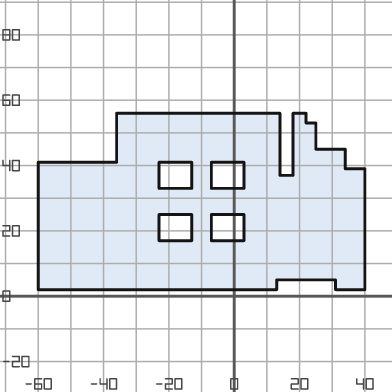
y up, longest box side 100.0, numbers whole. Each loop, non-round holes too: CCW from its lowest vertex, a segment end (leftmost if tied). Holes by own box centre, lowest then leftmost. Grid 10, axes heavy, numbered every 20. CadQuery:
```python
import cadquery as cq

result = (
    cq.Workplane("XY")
    .moveTo(-60.0, 2.0)
    .lineTo(13.0, 2.0)
    .lineTo(13.0, 5.0)
    .lineTo(31.0, 5.0)
    .lineTo(31.0, 2.0)
    .lineTo(40.0, 2.0)
    .lineTo(40.0, 39.0)
    .lineTo(34.0, 39.0)
    .lineTo(34.0, 45.0)
    .lineTo(25.0, 45.0)
    .lineTo(25.0, 53.0)
    .lineTo(22.0, 53.0)
    .lineTo(22.0, 56.0)
    .lineTo(18.0, 56.0)
    .lineTo(18.0, 37.0)
    .lineTo(14.0, 37.0)
    .lineTo(14.0, 56.0)
    .lineTo(-36.0, 56.0)
    .lineTo(-36.0, 41.0)
    .lineTo(-60.0, 41.0)
    .close()
    .moveTo(-23.0, 17.0)
    .lineTo(-13.0, 17.0)
    .lineTo(-13.0, 25.0)
    .lineTo(-23.0, 25.0)
    .close()
    .moveTo(-7.0, 17.0)
    .lineTo(3.0, 17.0)
    .lineTo(3.0, 25.0)
    .lineTo(-7.0, 25.0)
    .close()
    .moveTo(-23.0, 33.0)
    .lineTo(-13.0, 33.0)
    .lineTo(-13.0, 41.0)
    .lineTo(-23.0, 41.0)
    .close()
    .moveTo(-7.0, 33.0)
    .lineTo(3.0, 33.0)
    .lineTo(3.0, 41.0)
    .lineTo(-7.0, 41.0)
    .close()
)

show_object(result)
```